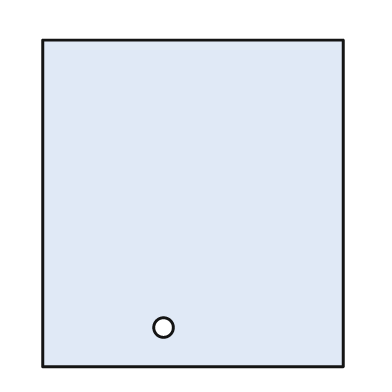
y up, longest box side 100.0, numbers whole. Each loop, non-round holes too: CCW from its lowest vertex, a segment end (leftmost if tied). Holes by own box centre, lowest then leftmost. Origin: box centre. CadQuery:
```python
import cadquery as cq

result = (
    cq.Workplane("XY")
    .moveTo(-46.0, -50.0)
    .lineTo(46.0, -50.0)
    .lineTo(46.0, 50.0)
    .lineTo(-46.0, 50.0)
    .close()
    .moveTo(-9.0, -38.0)
    .circle(3.0)
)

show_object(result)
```